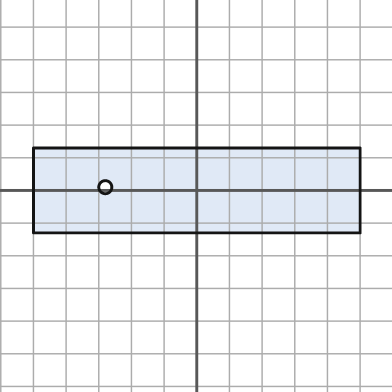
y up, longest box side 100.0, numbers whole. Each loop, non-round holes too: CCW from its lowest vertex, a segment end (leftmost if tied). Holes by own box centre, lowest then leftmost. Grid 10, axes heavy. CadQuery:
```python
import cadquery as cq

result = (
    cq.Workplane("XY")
    .moveTo(-50.0, -13.0)
    .lineTo(50.0, -13.0)
    .lineTo(50.0, 13.0)
    .lineTo(-50.0, 13.0)
    .close()
    .moveTo(-28.0, 1.0)
    .circle(2.0)
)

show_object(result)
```